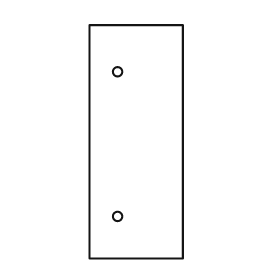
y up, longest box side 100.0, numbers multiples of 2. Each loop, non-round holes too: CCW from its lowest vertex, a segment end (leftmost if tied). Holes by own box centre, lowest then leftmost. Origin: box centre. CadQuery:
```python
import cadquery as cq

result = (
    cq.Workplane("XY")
    .moveTo(-20.0, -50.0)
    .lineTo(20.0, -50.0)
    .lineTo(20.0, 50.0)
    .lineTo(-20.0, 50.0)
    .close()
    .moveTo(-8.0, -32.0)
    .circle(2.0)
    .moveTo(-8.0, 30.0)
    .circle(2.0)
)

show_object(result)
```